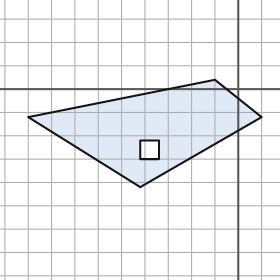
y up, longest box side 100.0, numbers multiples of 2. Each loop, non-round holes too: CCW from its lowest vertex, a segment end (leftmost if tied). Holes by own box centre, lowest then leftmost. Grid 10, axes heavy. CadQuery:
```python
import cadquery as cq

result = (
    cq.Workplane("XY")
    .moveTo(-42.0, -42.0)
    .lineTo(10.0, -12.0)
    .lineTo(-10.0, 4.0)
    .lineTo(-90.0, -12.0)
    .close()
    .moveTo(-42.0, -30.0)
    .lineTo(-34.0, -30.0)
    .lineTo(-34.0, -22.0)
    .lineTo(-42.0, -22.0)
    .close()
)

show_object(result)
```